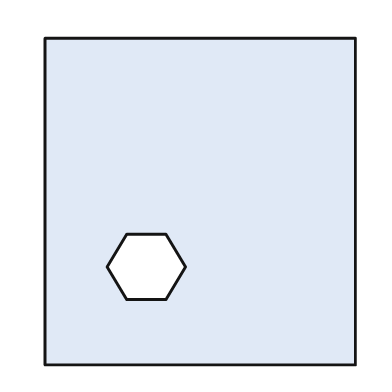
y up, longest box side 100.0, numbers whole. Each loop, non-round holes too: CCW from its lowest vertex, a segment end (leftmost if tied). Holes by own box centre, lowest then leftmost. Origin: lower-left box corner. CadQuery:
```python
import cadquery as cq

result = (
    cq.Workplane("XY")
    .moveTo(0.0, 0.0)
    .lineTo(95.0, 0.0)
    .lineTo(95.0, 100.0)
    .lineTo(0.0, 100.0)
    .close()
    .moveTo(25.0, 20.0)
    .lineTo(37.0, 20.0)
    .lineTo(43.0, 30.0)
    .lineTo(37.0, 40.0)
    .lineTo(25.0, 40.0)
    .lineTo(19.0, 30.0)
    .close()
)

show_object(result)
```